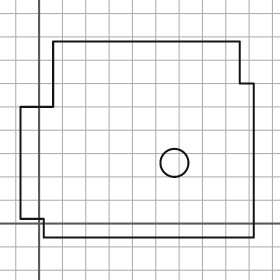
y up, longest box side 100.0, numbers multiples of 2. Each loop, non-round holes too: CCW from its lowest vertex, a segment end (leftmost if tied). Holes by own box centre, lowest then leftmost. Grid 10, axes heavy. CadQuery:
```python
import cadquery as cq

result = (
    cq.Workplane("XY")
    .moveTo(2.0, -6.0)
    .lineTo(92.0, -6.0)
    .lineTo(92.0, 60.0)
    .lineTo(86.0, 60.0)
    .lineTo(86.0, 78.0)
    .lineTo(6.0, 78.0)
    .lineTo(6.0, 50.0)
    .lineTo(-8.0, 50.0)
    .lineTo(-8.0, 2.0)
    .lineTo(2.0, 2.0)
    .close()
    .moveTo(58.0, 26.0)
    .circle(6.0)
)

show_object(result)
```